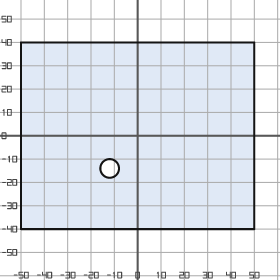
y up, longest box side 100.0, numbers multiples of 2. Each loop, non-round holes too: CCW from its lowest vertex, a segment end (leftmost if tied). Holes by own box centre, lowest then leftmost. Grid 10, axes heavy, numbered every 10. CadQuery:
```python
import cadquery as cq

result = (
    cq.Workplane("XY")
    .moveTo(-50.0, -40.0)
    .lineTo(50.0, -40.0)
    .lineTo(50.0, 40.0)
    .lineTo(-50.0, 40.0)
    .close()
    .moveTo(-12.0, -14.0)
    .circle(4.0)
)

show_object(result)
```